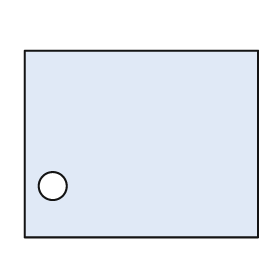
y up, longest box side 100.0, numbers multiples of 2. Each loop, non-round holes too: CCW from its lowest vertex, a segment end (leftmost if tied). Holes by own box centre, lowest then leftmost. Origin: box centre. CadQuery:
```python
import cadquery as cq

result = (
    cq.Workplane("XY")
    .moveTo(-50.0, -40.0)
    .lineTo(50.0, -40.0)
    .lineTo(50.0, 40.0)
    .lineTo(-50.0, 40.0)
    .close()
    .moveTo(-38.0, -18.0)
    .circle(6.0)
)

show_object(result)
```